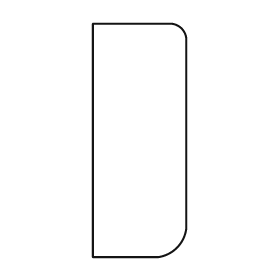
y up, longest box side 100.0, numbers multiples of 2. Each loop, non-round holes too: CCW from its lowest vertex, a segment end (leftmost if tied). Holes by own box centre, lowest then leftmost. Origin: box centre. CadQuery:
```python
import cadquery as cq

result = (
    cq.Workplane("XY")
    .moveTo(-20.0, -50.0)
    .lineTo(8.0, -50.0)
    .threePointArc((16.0, -46.0), (20.0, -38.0))
    .lineTo(20.0, 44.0)
    .threePointArc((18.0, 48.0), (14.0, 50.0))
    .lineTo(-20.0, 50.0)
    .close()
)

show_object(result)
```